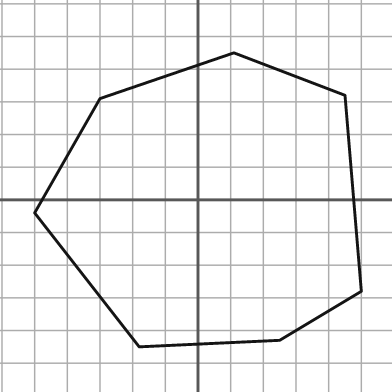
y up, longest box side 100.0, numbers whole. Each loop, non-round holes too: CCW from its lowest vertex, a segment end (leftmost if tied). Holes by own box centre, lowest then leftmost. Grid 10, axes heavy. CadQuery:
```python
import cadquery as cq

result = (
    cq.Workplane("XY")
    .moveTo(-18.0, -45.0)
    .lineTo(25.0, -43.0)
    .lineTo(50.0, -28.0)
    .lineTo(45.0, 32.0)
    .lineTo(11.0, 45.0)
    .lineTo(-30.0, 31.0)
    .lineTo(-50.0, -4.0)
    .close()
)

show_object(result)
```